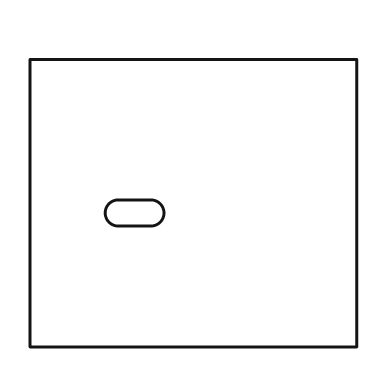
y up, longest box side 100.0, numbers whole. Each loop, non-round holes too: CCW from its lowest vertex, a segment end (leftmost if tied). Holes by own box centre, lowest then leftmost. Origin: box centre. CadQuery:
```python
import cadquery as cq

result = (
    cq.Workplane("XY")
    .moveTo(-50.0, -44.0)
    .lineTo(50.0, -44.0)
    .lineTo(50.0, 44.0)
    .lineTo(-50.0, 44.0)
    .close()
    .moveTo(-23.0, -7.0)
    .lineTo(-13.0, -7.0)
    .threePointArc((-9.0, -3.0), (-13.0, 1.0))
    .lineTo(-23.0, 1.0)
    .threePointArc((-27.0, -3.0), (-23.0, -7.0))
    .close()
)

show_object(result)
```